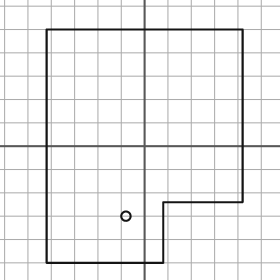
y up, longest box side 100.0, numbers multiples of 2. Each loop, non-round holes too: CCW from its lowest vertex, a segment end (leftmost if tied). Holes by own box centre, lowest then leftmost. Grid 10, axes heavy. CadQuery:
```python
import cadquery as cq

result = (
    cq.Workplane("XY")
    .moveTo(-42.0, -50.0)
    .lineTo(8.0, -50.0)
    .lineTo(8.0, -24.0)
    .lineTo(42.0, -24.0)
    .lineTo(42.0, 50.0)
    .lineTo(-42.0, 50.0)
    .close()
    .moveTo(-8.0, -30.0)
    .circle(2.0)
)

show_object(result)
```